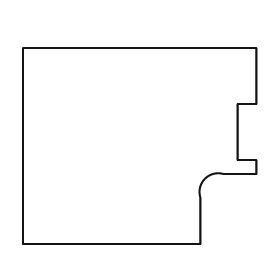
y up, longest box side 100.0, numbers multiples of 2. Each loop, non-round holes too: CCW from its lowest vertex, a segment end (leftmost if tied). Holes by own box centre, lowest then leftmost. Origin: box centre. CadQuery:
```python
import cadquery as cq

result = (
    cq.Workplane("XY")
    .moveTo(-50.0, -42.0)
    .lineTo(26.0, -42.0)
    .lineTo(26.0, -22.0)
    .threePointArc((28.0, -14.0), (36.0, -12.0))
    .lineTo(50.0, -12.0)
    .lineTo(50.0, -6.0)
    .lineTo(42.0, -6.0)
    .lineTo(42.0, 18.0)
    .lineTo(50.0, 18.0)
    .lineTo(50.0, 42.0)
    .lineTo(-50.0, 42.0)
    .close()
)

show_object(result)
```